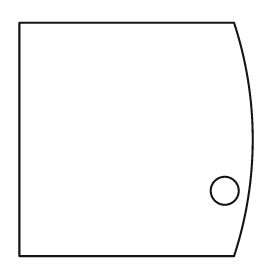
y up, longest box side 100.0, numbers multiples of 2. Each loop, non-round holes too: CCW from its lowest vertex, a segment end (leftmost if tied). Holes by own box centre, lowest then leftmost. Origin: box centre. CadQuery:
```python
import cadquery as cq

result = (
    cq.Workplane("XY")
    .moveTo(-50.0, -50.0)
    .lineTo(42.0, -50.0)
    .threePointArc((50.0, 0.0), (42.0, 50.0))
    .lineTo(-50.0, 50.0)
    .close()
    .moveTo(38.0, -22.0)
    .circle(6.0)
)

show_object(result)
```